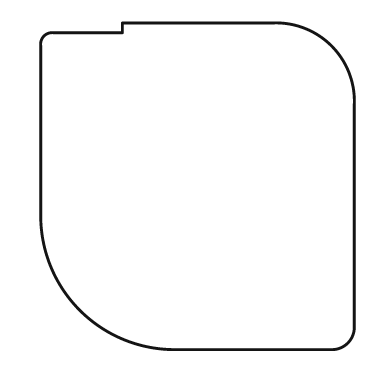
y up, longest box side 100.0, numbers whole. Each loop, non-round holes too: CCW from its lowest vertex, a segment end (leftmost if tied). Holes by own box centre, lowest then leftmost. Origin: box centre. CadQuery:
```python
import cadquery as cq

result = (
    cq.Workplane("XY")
    .moveTo(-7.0, -50.0)
    .lineTo(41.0, -50.0)
    .threePointArc((46.0, -48.0), (48.0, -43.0))
    .lineTo(48.0, 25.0)
    .threePointArc((41.0, 43.0), (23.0, 50.0))
    .lineTo(-23.0, 50.0)
    .lineTo(-23.0, 47.0)
    .lineTo(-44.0, 47.0)
    .threePointArc((-47.0, 46.0), (-48.0, 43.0))
    .lineTo(-48.0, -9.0)
    .threePointArc((-36.0, -38.0), (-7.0, -50.0))
    .close()
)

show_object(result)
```